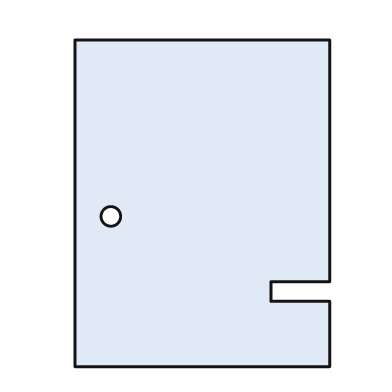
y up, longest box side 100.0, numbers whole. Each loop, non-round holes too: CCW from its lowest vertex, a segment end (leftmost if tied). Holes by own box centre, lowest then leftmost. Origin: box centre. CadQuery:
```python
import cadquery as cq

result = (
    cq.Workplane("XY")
    .moveTo(-39.0, -50.0)
    .lineTo(39.0, -50.0)
    .lineTo(39.0, -30.0)
    .lineTo(21.0, -30.0)
    .lineTo(21.0, -24.0)
    .lineTo(39.0, -24.0)
    .lineTo(39.0, 50.0)
    .lineTo(-39.0, 50.0)
    .close()
    .moveTo(-28.0, -4.0)
    .circle(3.0)
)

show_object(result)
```